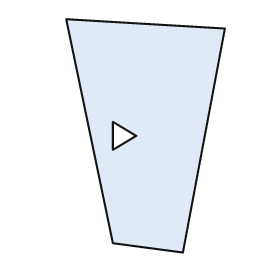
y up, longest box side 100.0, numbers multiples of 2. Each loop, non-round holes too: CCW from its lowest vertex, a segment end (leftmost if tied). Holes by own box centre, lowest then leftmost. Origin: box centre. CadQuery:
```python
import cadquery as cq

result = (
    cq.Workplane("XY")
    .moveTo(16.0, -50.0)
    .lineTo(34.0, 46.0)
    .lineTo(-34.0, 50.0)
    .lineTo(-14.0, -46.0)
    .close()
    .moveTo(-14.0, -6.0)
    .lineTo(-4.0, 0.0)
    .lineTo(-14.0, 6.0)
    .close()
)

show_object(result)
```